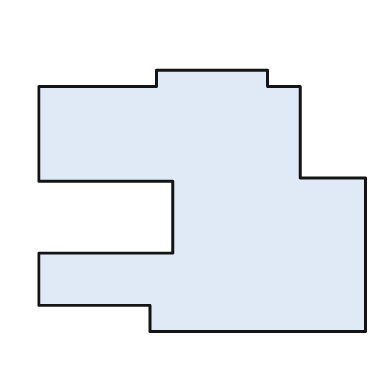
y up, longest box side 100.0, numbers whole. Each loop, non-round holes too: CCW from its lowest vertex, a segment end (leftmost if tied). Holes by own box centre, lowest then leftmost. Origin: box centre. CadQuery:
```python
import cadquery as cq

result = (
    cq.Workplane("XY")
    .moveTo(-16.0, -40.0)
    .lineTo(50.0, -40.0)
    .lineTo(50.0, 7.0)
    .lineTo(30.0, 7.0)
    .lineTo(30.0, 35.0)
    .lineTo(20.0, 35.0)
    .lineTo(20.0, 40.0)
    .lineTo(-14.0, 40.0)
    .lineTo(-14.0, 35.0)
    .lineTo(-50.0, 35.0)
    .lineTo(-50.0, 6.0)
    .lineTo(-9.0, 6.0)
    .lineTo(-9.0, -16.0)
    .lineTo(-50.0, -16.0)
    .lineTo(-50.0, -32.0)
    .lineTo(-16.0, -32.0)
    .close()
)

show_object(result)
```